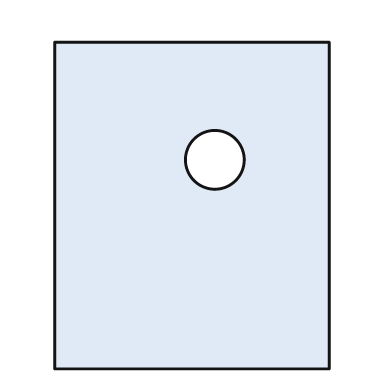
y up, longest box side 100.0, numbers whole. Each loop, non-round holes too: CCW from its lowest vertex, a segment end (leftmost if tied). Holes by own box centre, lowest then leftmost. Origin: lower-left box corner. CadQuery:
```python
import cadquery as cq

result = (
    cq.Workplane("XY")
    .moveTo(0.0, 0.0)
    .lineTo(84.0, 0.0)
    .lineTo(84.0, 100.0)
    .lineTo(0.0, 100.0)
    .close()
    .moveTo(49.0, 64.0)
    .circle(9.0)
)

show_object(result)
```